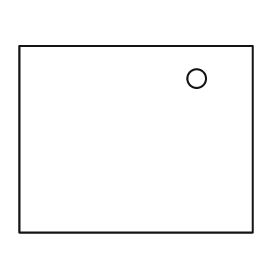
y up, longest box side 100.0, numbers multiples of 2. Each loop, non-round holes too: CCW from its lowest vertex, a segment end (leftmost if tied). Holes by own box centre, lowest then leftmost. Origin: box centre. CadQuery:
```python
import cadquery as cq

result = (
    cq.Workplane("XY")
    .moveTo(-50.0, -40.0)
    .lineTo(50.0, -40.0)
    .lineTo(50.0, 40.0)
    .lineTo(-50.0, 40.0)
    .close()
    .moveTo(26.0, 26.0)
    .circle(4.0)
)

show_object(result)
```